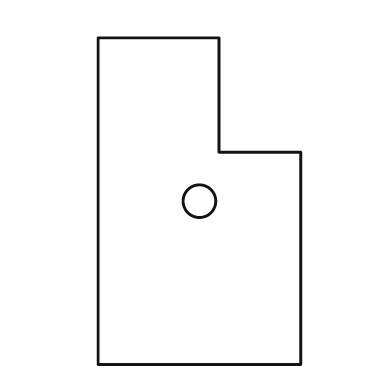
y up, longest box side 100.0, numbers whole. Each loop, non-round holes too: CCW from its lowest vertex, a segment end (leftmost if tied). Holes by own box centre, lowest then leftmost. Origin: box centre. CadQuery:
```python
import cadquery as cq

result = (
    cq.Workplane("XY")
    .moveTo(-31.0, -50.0)
    .lineTo(31.0, -50.0)
    .lineTo(31.0, 15.0)
    .lineTo(6.0, 15.0)
    .lineTo(6.0, 50.0)
    .lineTo(-31.0, 50.0)
    .close()
    .moveTo(0.0, 0.0)
    .circle(5.0)
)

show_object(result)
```